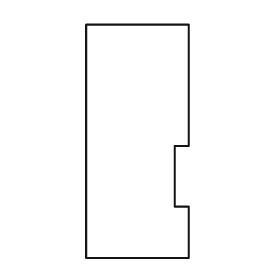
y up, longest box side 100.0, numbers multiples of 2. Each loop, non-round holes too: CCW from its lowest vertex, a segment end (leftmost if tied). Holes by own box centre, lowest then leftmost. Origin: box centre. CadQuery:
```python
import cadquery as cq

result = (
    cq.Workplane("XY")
    .moveTo(-22.0, -50.0)
    .lineTo(22.0, -50.0)
    .lineTo(22.0, -28.0)
    .lineTo(16.0, -28.0)
    .lineTo(16.0, -2.0)
    .lineTo(22.0, -2.0)
    .lineTo(22.0, 50.0)
    .lineTo(-22.0, 50.0)
    .close()
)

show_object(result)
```